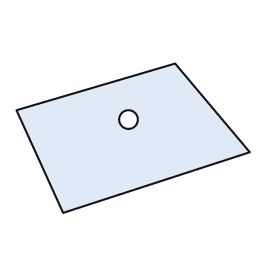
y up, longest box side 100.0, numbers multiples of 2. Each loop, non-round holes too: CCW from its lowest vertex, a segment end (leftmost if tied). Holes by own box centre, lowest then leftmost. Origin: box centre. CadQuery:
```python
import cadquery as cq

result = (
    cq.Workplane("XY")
    .moveTo(-30.0, -32.0)
    .lineTo(50.0, -6.0)
    .lineTo(18.0, 32.0)
    .lineTo(-50.0, 12.0)
    .close()
    .moveTo(-2.0, 8.0)
    .circle(4.0)
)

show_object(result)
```